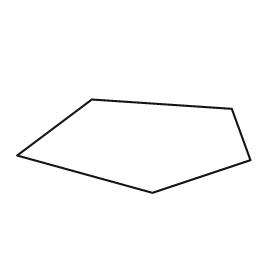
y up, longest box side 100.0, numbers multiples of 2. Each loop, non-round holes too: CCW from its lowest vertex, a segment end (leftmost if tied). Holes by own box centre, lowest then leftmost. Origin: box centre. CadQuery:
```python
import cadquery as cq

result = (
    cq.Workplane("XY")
    .moveTo(8.0, -20.0)
    .lineTo(50.0, -6.0)
    .lineTo(42.0, 16.0)
    .lineTo(-18.0, 20.0)
    .lineTo(-50.0, -4.0)
    .close()
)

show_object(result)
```